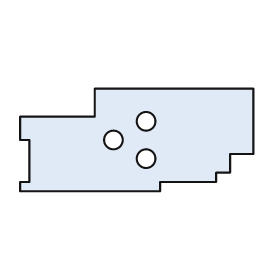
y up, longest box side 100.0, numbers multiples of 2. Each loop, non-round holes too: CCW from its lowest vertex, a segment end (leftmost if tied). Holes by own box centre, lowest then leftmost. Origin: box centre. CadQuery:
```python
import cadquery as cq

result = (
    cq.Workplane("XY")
    .moveTo(-50.0, -22.0)
    .lineTo(10.0, -22.0)
    .lineTo(10.0, -18.0)
    .lineTo(34.0, -18.0)
    .lineTo(34.0, -14.0)
    .lineTo(40.0, -14.0)
    .lineTo(40.0, -6.0)
    .lineTo(50.0, -6.0)
    .lineTo(50.0, 22.0)
    .lineTo(-18.0, 22.0)
    .lineTo(-18.0, 10.0)
    .lineTo(-50.0, 10.0)
    .lineTo(-50.0, 0.0)
    .lineTo(-46.0, 0.0)
    .lineTo(-46.0, -18.0)
    .lineTo(-50.0, -18.0)
    .close()
    .moveTo(4.0, -8.0)
    .circle(4.0)
    .moveTo(-10.0, 0.0)
    .circle(4.0)
    .moveTo(4.0, 8.0)
    .circle(4.0)
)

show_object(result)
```